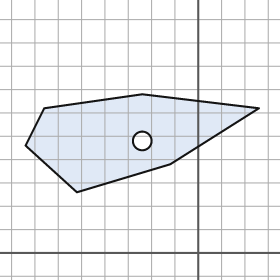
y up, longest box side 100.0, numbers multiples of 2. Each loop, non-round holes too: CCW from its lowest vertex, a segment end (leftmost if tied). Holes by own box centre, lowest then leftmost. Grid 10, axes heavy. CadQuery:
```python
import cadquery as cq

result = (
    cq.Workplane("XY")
    .moveTo(-52.0, 26.0)
    .lineTo(-12.0, 38.0)
    .lineTo(26.0, 62.0)
    .lineTo(-24.0, 68.0)
    .lineTo(-66.0, 62.0)
    .lineTo(-74.0, 46.0)
    .close()
    .moveTo(-24.0, 48.0)
    .circle(4.0)
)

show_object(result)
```